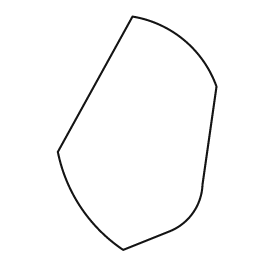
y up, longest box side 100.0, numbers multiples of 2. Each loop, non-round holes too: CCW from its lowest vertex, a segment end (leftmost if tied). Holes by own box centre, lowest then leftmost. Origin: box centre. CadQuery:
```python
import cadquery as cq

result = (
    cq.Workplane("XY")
    .moveTo(-6.0, -50.0)
    .lineTo(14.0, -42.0)
    .threePointArc((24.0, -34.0), (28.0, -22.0))
    .lineTo(34.0, 20.0)
    .threePointArc((20.0, 40.0), (-2.0, 50.0))
    .lineTo(-34.0, -8.0)
    .threePointArc((-24.0, -32.0), (-6.0, -50.0))
    .close()
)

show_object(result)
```